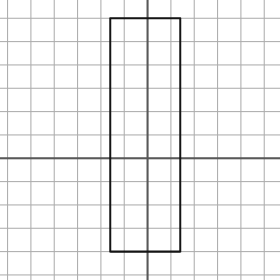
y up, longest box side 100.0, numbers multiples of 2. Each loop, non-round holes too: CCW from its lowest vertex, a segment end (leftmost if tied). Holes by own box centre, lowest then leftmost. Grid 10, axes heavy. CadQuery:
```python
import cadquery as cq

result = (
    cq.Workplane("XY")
    .moveTo(-16.0, -40.0)
    .lineTo(14.0, -40.0)
    .lineTo(14.0, 60.0)
    .lineTo(-16.0, 60.0)
    .close()
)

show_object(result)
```